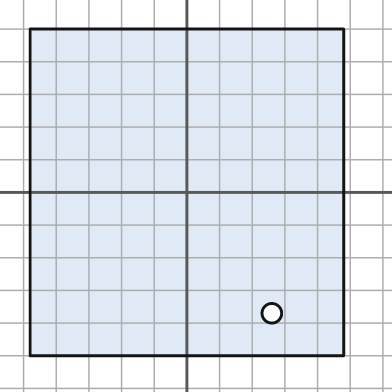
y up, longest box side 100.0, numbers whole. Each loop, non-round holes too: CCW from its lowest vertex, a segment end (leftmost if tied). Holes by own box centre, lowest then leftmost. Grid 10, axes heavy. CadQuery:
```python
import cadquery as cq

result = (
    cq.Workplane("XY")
    .moveTo(-48.0, -50.0)
    .lineTo(48.0, -50.0)
    .lineTo(48.0, 50.0)
    .lineTo(-48.0, 50.0)
    .close()
    .moveTo(26.0, -37.0)
    .circle(3.0)
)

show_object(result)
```